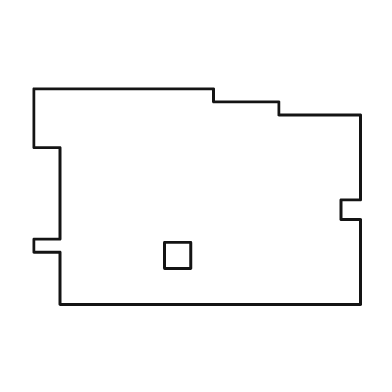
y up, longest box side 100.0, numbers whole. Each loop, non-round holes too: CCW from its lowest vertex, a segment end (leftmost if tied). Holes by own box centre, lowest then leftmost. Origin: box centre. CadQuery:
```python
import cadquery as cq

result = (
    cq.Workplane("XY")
    .moveTo(-42.0, -33.0)
    .lineTo(50.0, -33.0)
    .lineTo(50.0, -7.0)
    .lineTo(44.0, -7.0)
    .lineTo(44.0, -1.0)
    .lineTo(50.0, -1.0)
    .lineTo(50.0, 25.0)
    .lineTo(25.0, 25.0)
    .lineTo(25.0, 29.0)
    .lineTo(5.0, 29.0)
    .lineTo(5.0, 33.0)
    .lineTo(-50.0, 33.0)
    .lineTo(-50.0, 15.0)
    .lineTo(-42.0, 15.0)
    .lineTo(-42.0, -13.0)
    .lineTo(-50.0, -13.0)
    .lineTo(-50.0, -17.0)
    .lineTo(-42.0, -17.0)
    .close()
    .moveTo(-10.0, -22.0)
    .lineTo(-2.0, -22.0)
    .lineTo(-2.0, -14.0)
    .lineTo(-10.0, -14.0)
    .close()
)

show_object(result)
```